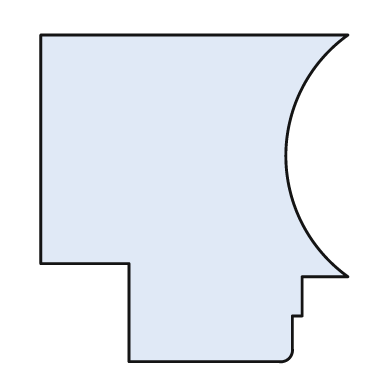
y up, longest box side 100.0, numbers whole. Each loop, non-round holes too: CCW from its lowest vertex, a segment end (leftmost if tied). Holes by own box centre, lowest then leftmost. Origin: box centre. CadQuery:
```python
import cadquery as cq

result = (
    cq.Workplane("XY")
    .moveTo(-20.0, -50.0)
    .lineTo(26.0, -50.0)
    .threePointArc((29.0, -49.0), (30.0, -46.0))
    .lineTo(30.0, -36.0)
    .lineTo(33.0, -36.0)
    .lineTo(33.0, -24.0)
    .lineTo(47.0, -24.0)
    .threePointArc((28.0, 13.0), (47.0, 50.0))
    .lineTo(-47.0, 50.0)
    .lineTo(-47.0, -20.0)
    .lineTo(-20.0, -20.0)
    .close()
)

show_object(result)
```